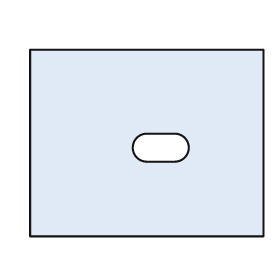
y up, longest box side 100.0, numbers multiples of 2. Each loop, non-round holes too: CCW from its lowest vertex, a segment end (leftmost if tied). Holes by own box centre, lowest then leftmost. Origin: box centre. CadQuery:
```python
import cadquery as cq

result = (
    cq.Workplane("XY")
    .moveTo(-50.0, -40.0)
    .lineTo(50.0, -40.0)
    .lineTo(50.0, 40.0)
    .lineTo(-50.0, 40.0)
    .close()
    .moveTo(0.0, -8.0)
    .lineTo(12.0, -8.0)
    .threePointArc((18.0, -2.0), (12.0, 4.0))
    .lineTo(0.0, 4.0)
    .threePointArc((-6.0, -2.0), (0.0, -8.0))
    .close()
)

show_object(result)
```